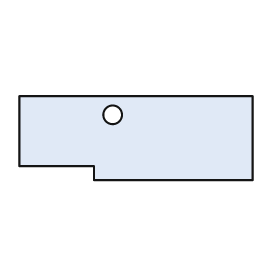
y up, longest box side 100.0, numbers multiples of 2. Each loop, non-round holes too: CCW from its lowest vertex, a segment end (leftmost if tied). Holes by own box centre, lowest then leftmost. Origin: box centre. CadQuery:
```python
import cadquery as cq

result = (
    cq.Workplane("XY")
    .moveTo(-18.0, -18.0)
    .lineTo(50.0, -18.0)
    .lineTo(50.0, 18.0)
    .lineTo(-50.0, 18.0)
    .lineTo(-50.0, -12.0)
    .lineTo(-18.0, -12.0)
    .close()
    .moveTo(-10.0, 10.0)
    .circle(4.0)
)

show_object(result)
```